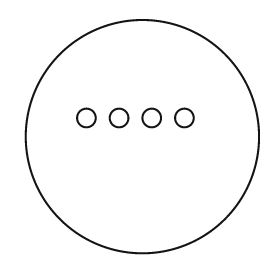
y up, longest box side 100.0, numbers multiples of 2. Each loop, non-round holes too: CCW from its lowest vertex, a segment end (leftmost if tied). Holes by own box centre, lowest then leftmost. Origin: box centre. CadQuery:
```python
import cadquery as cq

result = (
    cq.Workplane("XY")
    .moveTo(0.0, 0.0)
    .circle(50.0)
    .moveTo(-24.0, 8.0)
    .circle(4.0)
    .moveTo(-10.0, 8.0)
    .circle(4.0)
    .moveTo(4.0, 8.0)
    .circle(4.0)
    .moveTo(18.0, 8.0)
    .circle(4.0)
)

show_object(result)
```